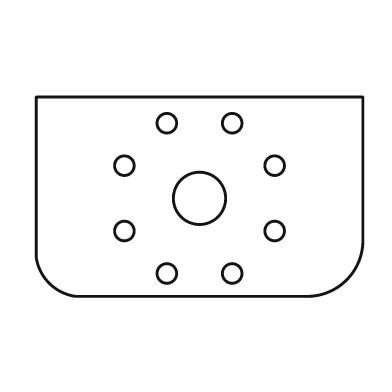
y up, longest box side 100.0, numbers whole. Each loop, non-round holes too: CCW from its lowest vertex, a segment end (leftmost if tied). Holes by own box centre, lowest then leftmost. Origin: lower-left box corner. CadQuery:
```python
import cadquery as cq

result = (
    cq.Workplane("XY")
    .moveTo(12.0, 0.0)
    .lineTo(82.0, 0.0)
    .threePointArc((95.0, 5.0), (100.0, 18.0))
    .lineTo(100.0, 61.0)
    .lineTo(0.0, 61.0)
    .lineTo(0.0, 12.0)
    .threePointArc((4.0, 4.0), (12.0, 0.0))
    .close()
    .moveTo(40.0, 7.0)
    .circle(3.0)
    .moveTo(60.0, 7.0)
    .circle(3.0)
    .moveTo(27.0, 20.0)
    .circle(3.0)
    .moveTo(73.0, 20.0)
    .circle(3.0)
    .moveTo(50.0, 30.0)
    .circle(8.0)
    .moveTo(27.0, 40.0)
    .circle(3.0)
    .moveTo(73.0, 40.0)
    .circle(3.0)
    .moveTo(40.0, 53.0)
    .circle(3.0)
    .moveTo(60.0, 53.0)
    .circle(3.0)
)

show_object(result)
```